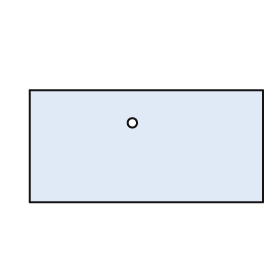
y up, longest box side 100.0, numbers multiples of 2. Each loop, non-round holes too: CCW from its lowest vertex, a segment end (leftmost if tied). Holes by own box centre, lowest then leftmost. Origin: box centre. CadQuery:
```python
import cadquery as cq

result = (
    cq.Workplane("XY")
    .moveTo(-50.0, -24.0)
    .lineTo(50.0, -24.0)
    .lineTo(50.0, 24.0)
    .lineTo(-50.0, 24.0)
    .close()
    .moveTo(-6.0, 10.0)
    .circle(2.0)
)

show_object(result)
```